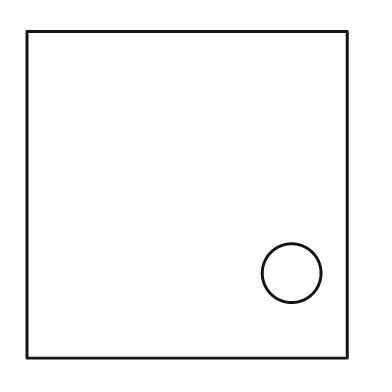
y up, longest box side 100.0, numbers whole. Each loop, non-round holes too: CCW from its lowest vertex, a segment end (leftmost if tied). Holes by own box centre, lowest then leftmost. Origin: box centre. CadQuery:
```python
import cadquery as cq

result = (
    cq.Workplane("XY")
    .moveTo(-49.0, -50.0)
    .lineTo(49.0, -50.0)
    .lineTo(49.0, 50.0)
    .lineTo(-49.0, 50.0)
    .close()
    .moveTo(32.0, -24.0)
    .circle(9.0)
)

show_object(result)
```